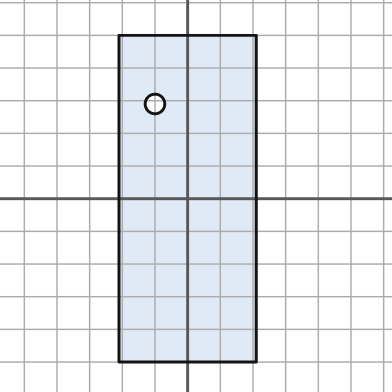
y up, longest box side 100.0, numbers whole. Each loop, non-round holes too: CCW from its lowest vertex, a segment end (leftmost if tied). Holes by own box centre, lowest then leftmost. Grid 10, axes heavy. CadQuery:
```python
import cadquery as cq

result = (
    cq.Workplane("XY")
    .moveTo(-21.0, -50.0)
    .lineTo(21.0, -50.0)
    .lineTo(21.0, 50.0)
    .lineTo(-21.0, 50.0)
    .close()
    .moveTo(-10.0, 29.0)
    .circle(3.0)
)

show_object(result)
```